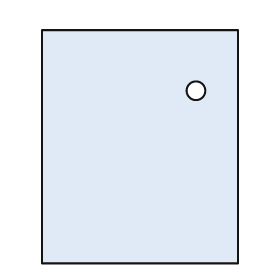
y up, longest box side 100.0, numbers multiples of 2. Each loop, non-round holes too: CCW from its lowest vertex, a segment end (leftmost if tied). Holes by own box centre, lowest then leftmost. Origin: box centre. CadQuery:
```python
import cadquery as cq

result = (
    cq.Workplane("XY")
    .moveTo(-42.0, -50.0)
    .lineTo(42.0, -50.0)
    .lineTo(42.0, 50.0)
    .lineTo(-42.0, 50.0)
    .close()
    .moveTo(24.0, 24.0)
    .circle(4.0)
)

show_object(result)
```